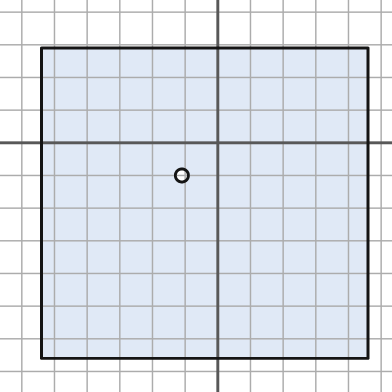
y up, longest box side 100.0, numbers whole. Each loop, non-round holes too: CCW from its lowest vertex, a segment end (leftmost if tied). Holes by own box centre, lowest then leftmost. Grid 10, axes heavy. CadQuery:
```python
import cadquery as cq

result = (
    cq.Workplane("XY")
    .moveTo(-54.0, -66.0)
    .lineTo(46.0, -66.0)
    .lineTo(46.0, 29.0)
    .lineTo(-54.0, 29.0)
    .close()
    .moveTo(-11.0, -10.0)
    .circle(2.0)
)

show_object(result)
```